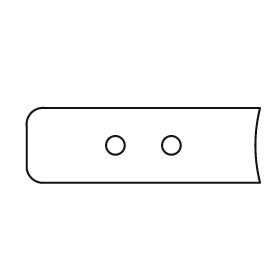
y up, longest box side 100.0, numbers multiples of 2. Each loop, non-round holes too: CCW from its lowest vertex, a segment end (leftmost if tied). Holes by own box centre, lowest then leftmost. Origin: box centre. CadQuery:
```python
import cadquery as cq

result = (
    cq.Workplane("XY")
    .moveTo(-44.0, -16.0)
    .lineTo(50.0, -16.0)
    .threePointArc((48.0, 0.0), (50.0, 16.0))
    .lineTo(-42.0, 16.0)
    .threePointArc((-48.0, 14.0), (-50.0, 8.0))
    .lineTo(-50.0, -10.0)
    .threePointArc((-48.0, -14.0), (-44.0, -16.0))
    .close()
    .moveTo(-12.0, 0.0)
    .circle(4.0)
    .moveTo(12.0, 0.0)
    .circle(4.0)
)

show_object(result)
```